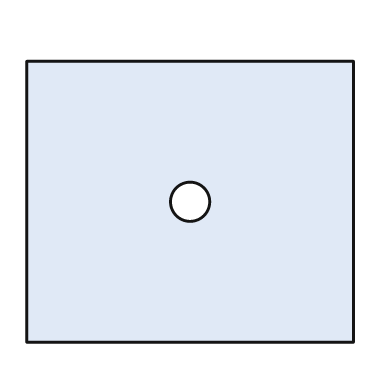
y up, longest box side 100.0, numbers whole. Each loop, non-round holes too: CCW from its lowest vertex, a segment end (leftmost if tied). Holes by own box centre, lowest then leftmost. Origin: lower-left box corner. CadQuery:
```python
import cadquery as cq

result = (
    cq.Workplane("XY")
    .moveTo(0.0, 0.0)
    .lineTo(100.0, 0.0)
    .lineTo(100.0, 86.0)
    .lineTo(0.0, 86.0)
    .close()
    .moveTo(50.0, 43.0)
    .circle(6.0)
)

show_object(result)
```